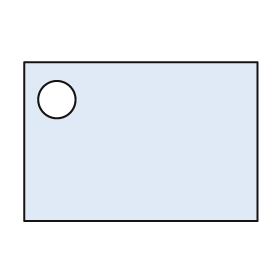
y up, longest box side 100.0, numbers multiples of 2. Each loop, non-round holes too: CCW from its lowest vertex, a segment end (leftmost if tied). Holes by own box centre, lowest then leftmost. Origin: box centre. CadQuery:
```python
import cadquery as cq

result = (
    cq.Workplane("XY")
    .moveTo(-50.0, -34.0)
    .lineTo(50.0, -34.0)
    .lineTo(50.0, 34.0)
    .lineTo(-50.0, 34.0)
    .close()
    .moveTo(-36.0, 18.0)
    .circle(8.0)
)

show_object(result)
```